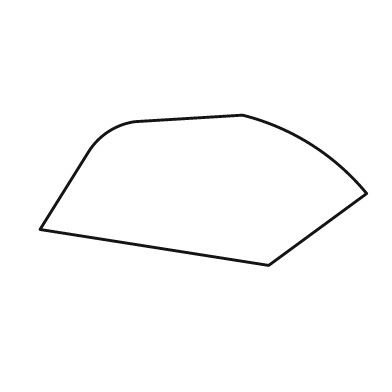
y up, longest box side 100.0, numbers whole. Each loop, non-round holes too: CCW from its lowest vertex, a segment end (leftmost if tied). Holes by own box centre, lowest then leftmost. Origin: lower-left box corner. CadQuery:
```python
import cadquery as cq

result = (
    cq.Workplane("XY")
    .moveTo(70.0, 0.0)
    .lineTo(100.0, 22.0)
    .threePointArc((83.0, 37.0), (62.0, 46.0))
    .lineTo(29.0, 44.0)
    .threePointArc((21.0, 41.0), (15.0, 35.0))
    .lineTo(0.0, 11.0)
    .close()
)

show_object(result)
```